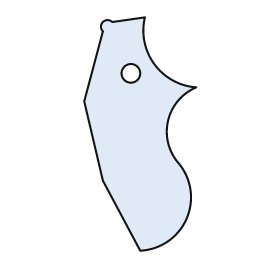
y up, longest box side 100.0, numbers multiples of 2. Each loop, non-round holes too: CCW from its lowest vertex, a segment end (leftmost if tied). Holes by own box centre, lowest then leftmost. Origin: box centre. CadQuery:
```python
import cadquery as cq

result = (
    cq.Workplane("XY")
    .moveTo(0.0, -50.0)
    .threePointArc((20.0, -36.0), (16.0, -12.0))
    .threePointArc((12.0, 6.0), (24.0, 20.0))
    .threePointArc((6.0, 30.0), (2.0, 50.0))
    .lineTo(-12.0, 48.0)
    .threePointArc((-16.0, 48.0), (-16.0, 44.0))
    .lineTo(-24.0, 14.0)
    .lineTo(-16.0, -20.0)
    .close()
    .moveTo(-4.0, 26.0)
    .circle(4.0)
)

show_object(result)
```